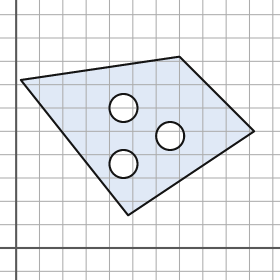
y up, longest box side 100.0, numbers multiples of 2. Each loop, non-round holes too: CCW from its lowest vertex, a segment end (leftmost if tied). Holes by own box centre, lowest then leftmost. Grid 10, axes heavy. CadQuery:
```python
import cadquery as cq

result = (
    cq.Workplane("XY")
    .moveTo(48.0, 14.0)
    .lineTo(102.0, 50.0)
    .lineTo(70.0, 82.0)
    .lineTo(2.0, 72.0)
    .close()
    .moveTo(46.0, 36.0)
    .circle(6.0)
    .moveTo(66.0, 48.0)
    .circle(6.0)
    .moveTo(46.0, 60.0)
    .circle(6.0)
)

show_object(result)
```